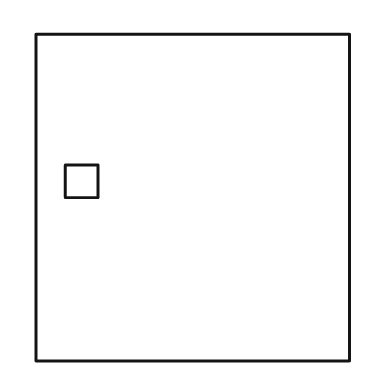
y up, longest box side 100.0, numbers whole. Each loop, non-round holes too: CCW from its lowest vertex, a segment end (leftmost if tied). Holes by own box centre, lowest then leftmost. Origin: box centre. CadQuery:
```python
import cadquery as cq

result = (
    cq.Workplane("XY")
    .moveTo(-48.0, -50.0)
    .lineTo(48.0, -50.0)
    .lineTo(48.0, 50.0)
    .lineTo(-48.0, 50.0)
    .close()
    .moveTo(-39.0, 0.0)
    .lineTo(-29.0, 0.0)
    .lineTo(-29.0, 10.0)
    .lineTo(-39.0, 10.0)
    .close()
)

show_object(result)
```